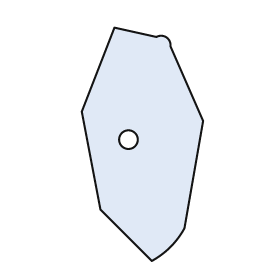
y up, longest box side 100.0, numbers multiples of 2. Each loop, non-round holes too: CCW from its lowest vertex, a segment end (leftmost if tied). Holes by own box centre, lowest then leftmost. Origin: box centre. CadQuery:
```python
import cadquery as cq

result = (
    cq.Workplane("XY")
    .moveTo(4.0, -50.0)
    .threePointArc((12.0, -44.0), (18.0, -36.0))
    .lineTo(26.0, 10.0)
    .lineTo(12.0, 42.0)
    .threePointArc((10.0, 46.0), (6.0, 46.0))
    .lineTo(-12.0, 50.0)
    .lineTo(-26.0, 14.0)
    .lineTo(-18.0, -28.0)
    .close()
    .moveTo(-6.0, 2.0)
    .circle(4.0)
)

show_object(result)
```